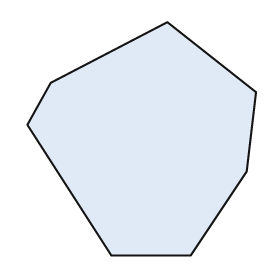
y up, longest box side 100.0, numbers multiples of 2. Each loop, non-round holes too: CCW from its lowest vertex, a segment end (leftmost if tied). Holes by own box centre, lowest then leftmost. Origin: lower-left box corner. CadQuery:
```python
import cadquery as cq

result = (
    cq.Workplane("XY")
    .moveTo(36.0, 0.0)
    .lineTo(70.0, 0.0)
    .lineTo(94.0, 36.0)
    .lineTo(98.0, 70.0)
    .lineTo(60.0, 100.0)
    .lineTo(10.0, 74.0)
    .lineTo(0.0, 56.0)
    .close()
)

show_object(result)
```